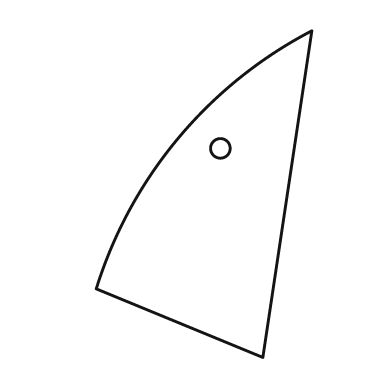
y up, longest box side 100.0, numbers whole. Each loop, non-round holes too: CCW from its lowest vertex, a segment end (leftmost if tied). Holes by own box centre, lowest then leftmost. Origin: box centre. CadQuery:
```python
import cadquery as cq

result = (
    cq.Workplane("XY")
    .moveTo(18.0, -50.0)
    .lineTo(33.0, 50.0)
    .threePointArc((-8.0, 17.0), (-33.0, -29.0))
    .close()
    .moveTo(5.0, 14.0)
    .circle(3.0)
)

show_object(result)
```